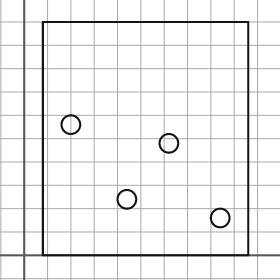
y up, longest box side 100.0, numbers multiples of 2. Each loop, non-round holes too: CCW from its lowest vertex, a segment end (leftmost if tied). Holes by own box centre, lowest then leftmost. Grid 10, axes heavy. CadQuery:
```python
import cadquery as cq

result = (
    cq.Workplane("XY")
    .moveTo(8.0, 0.0)
    .lineTo(96.0, 0.0)
    .lineTo(96.0, 100.0)
    .lineTo(8.0, 100.0)
    .close()
    .moveTo(84.0, 16.0)
    .circle(4.0)
    .moveTo(44.0, 24.0)
    .circle(4.0)
    .moveTo(62.0, 48.0)
    .circle(4.0)
    .moveTo(20.0, 56.0)
    .circle(4.0)
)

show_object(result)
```